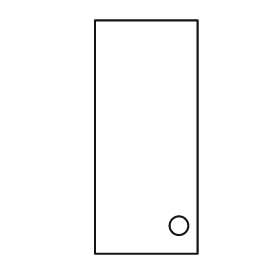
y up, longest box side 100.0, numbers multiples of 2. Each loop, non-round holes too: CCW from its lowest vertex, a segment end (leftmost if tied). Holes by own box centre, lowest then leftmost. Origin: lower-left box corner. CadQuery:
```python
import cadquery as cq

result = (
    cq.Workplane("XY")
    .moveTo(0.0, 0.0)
    .lineTo(44.0, 0.0)
    .lineTo(44.0, 100.0)
    .lineTo(0.0, 100.0)
    .close()
    .moveTo(36.0, 12.0)
    .circle(4.0)
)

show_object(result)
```